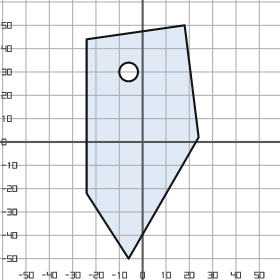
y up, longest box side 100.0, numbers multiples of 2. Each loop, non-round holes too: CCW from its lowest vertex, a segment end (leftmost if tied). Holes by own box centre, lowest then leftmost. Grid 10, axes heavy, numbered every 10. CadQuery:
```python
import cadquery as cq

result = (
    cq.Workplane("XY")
    .moveTo(-6.0, -50.0)
    .lineTo(24.0, 2.0)
    .lineTo(18.0, 50.0)
    .lineTo(-24.0, 44.0)
    .lineTo(-24.0, -22.0)
    .close()
    .moveTo(-6.0, 30.0)
    .circle(4.0)
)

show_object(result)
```